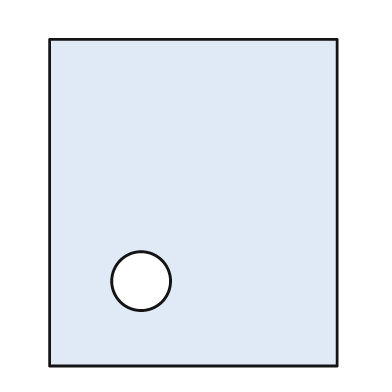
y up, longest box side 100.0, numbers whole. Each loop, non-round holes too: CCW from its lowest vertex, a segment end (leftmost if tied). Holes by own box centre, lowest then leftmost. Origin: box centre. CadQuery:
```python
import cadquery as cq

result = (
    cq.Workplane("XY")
    .moveTo(-44.0, -50.0)
    .lineTo(44.0, -50.0)
    .lineTo(44.0, 50.0)
    .lineTo(-44.0, 50.0)
    .close()
    .moveTo(-16.0, -24.0)
    .circle(9.0)
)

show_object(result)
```